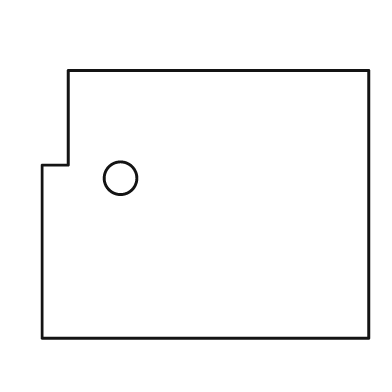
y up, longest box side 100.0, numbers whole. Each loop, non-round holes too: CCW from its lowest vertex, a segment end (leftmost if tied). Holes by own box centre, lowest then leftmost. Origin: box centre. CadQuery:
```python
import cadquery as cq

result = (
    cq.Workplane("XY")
    .moveTo(-50.0, -41.0)
    .lineTo(50.0, -41.0)
    .lineTo(50.0, 41.0)
    .lineTo(-42.0, 41.0)
    .lineTo(-42.0, 12.0)
    .lineTo(-50.0, 12.0)
    .close()
    .moveTo(-26.0, 8.0)
    .circle(5.0)
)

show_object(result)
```